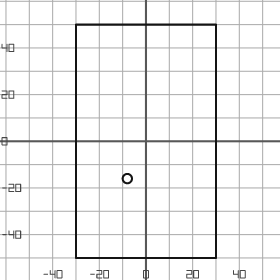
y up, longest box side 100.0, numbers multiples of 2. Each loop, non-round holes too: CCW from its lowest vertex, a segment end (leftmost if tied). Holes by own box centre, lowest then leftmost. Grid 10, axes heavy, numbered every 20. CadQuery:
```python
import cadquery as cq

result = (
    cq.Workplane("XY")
    .moveTo(-30.0, -50.0)
    .lineTo(30.0, -50.0)
    .lineTo(30.0, 50.0)
    .lineTo(-30.0, 50.0)
    .close()
    .moveTo(-8.0, -16.0)
    .circle(2.0)
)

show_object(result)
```